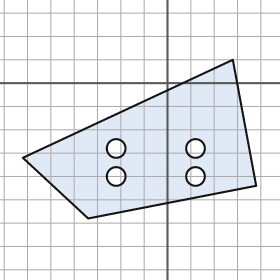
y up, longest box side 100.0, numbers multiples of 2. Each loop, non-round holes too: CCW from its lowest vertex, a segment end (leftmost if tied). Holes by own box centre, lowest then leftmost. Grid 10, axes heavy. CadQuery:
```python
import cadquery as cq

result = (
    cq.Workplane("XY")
    .moveTo(-34.0, -58.0)
    .lineTo(38.0, -44.0)
    .lineTo(28.0, 10.0)
    .lineTo(-62.0, -32.0)
    .close()
    .moveTo(-22.0, -40.0)
    .circle(4.0)
    .moveTo(12.0, -40.0)
    .circle(4.0)
    .moveTo(-22.0, -28.0)
    .circle(4.0)
    .moveTo(12.0, -28.0)
    .circle(4.0)
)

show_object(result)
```